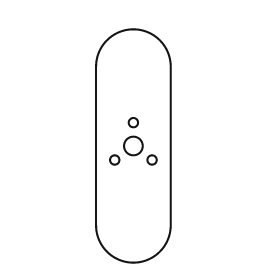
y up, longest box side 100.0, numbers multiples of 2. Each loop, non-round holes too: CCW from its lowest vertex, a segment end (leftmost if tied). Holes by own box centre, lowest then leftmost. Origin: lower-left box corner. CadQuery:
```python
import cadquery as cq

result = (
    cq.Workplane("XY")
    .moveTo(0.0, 16.0)
    .threePointArc((16.0, 0.0), (32.0, 16.0))
    .lineTo(32.0, 84.0)
    .threePointArc((16.0, 100.0), (0.0, 84.0))
    .close()
    .moveTo(8.0, 44.0)
    .circle(2.0)
    .moveTo(24.0, 44.0)
    .circle(2.0)
    .moveTo(16.0, 50.0)
    .circle(4.0)
    .moveTo(16.0, 60.0)
    .circle(2.0)
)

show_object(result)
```